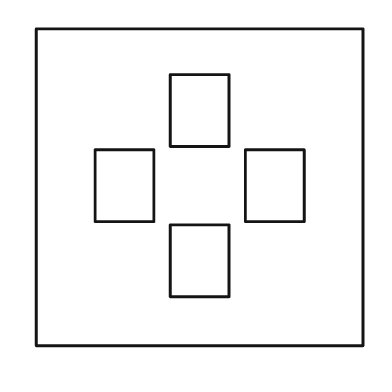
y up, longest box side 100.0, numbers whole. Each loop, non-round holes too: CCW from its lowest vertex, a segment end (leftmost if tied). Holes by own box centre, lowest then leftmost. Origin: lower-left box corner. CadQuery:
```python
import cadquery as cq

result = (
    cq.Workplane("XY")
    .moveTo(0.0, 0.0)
    .lineTo(100.0, 0.0)
    .lineTo(100.0, 97.0)
    .lineTo(0.0, 97.0)
    .close()
    .moveTo(41.0, 15.0)
    .lineTo(59.0, 15.0)
    .lineTo(59.0, 37.0)
    .lineTo(41.0, 37.0)
    .close()
    .moveTo(18.0, 38.0)
    .lineTo(36.0, 38.0)
    .lineTo(36.0, 60.0)
    .lineTo(18.0, 60.0)
    .close()
    .moveTo(64.0, 38.0)
    .lineTo(82.0, 38.0)
    .lineTo(82.0, 60.0)
    .lineTo(64.0, 60.0)
    .close()
    .moveTo(41.0, 61.0)
    .lineTo(59.0, 61.0)
    .lineTo(59.0, 83.0)
    .lineTo(41.0, 83.0)
    .close()
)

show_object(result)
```